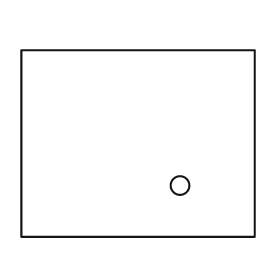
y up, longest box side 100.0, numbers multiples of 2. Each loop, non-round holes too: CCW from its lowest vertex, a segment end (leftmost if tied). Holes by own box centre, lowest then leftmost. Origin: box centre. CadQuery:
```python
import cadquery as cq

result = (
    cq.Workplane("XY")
    .moveTo(-50.0, -40.0)
    .lineTo(50.0, -40.0)
    .lineTo(50.0, 40.0)
    .lineTo(-50.0, 40.0)
    .close()
    .moveTo(18.0, -18.0)
    .circle(4.0)
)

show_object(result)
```